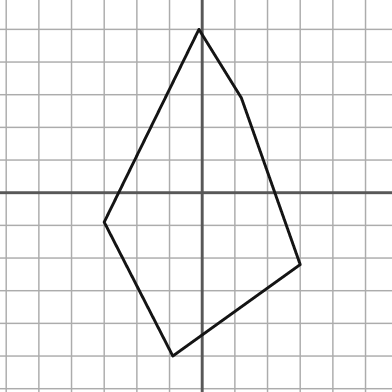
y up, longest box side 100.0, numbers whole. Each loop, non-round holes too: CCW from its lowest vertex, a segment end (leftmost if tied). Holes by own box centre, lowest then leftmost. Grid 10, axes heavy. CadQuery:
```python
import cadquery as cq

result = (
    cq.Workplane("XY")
    .moveTo(-9.0, -50.0)
    .lineTo(30.0, -22.0)
    .lineTo(12.0, 29.0)
    .lineTo(-1.0, 50.0)
    .lineTo(-30.0, -9.0)
    .close()
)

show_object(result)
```